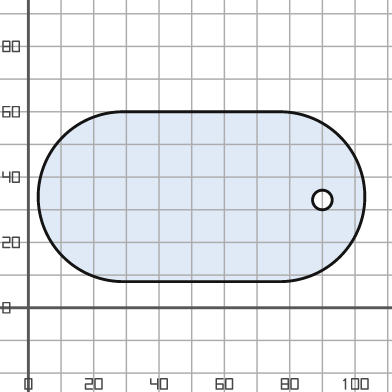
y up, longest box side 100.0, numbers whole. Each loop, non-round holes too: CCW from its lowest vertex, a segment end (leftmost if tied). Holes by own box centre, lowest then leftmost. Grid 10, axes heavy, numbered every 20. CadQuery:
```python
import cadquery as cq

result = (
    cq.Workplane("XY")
    .moveTo(29.0, 8.0)
    .lineTo(77.0, 8.0)
    .threePointArc((103.0, 34.0), (77.0, 60.0))
    .lineTo(29.0, 60.0)
    .threePointArc((3.0, 34.0), (29.0, 8.0))
    .close()
    .moveTo(90.0, 33.0)
    .circle(3.0)
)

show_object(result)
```